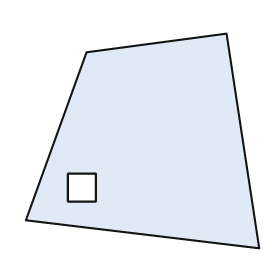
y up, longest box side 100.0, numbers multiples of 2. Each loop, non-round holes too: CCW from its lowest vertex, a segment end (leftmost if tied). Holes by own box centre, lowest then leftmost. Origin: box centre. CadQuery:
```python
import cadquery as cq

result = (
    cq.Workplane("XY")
    .moveTo(50.0, -46.0)
    .lineTo(36.0, 46.0)
    .lineTo(-24.0, 38.0)
    .lineTo(-50.0, -34.0)
    .close()
    .moveTo(-32.0, -26.0)
    .lineTo(-20.0, -26.0)
    .lineTo(-20.0, -14.0)
    .lineTo(-32.0, -14.0)
    .close()
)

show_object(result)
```